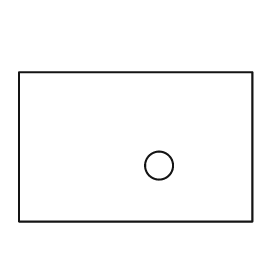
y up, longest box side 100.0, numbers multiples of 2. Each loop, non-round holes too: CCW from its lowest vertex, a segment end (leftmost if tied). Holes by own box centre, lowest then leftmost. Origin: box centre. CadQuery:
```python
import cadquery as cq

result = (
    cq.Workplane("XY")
    .moveTo(-50.0, -32.0)
    .lineTo(50.0, -32.0)
    .lineTo(50.0, 32.0)
    .lineTo(-50.0, 32.0)
    .close()
    .moveTo(10.0, -8.0)
    .circle(6.0)
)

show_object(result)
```